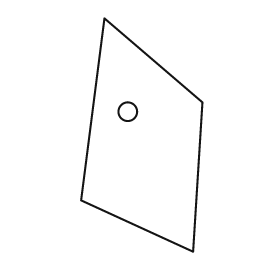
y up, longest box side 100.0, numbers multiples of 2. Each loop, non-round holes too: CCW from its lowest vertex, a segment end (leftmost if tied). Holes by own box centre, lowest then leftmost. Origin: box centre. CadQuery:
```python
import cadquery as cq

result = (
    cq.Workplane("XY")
    .moveTo(22.0, -50.0)
    .lineTo(26.0, 14.0)
    .lineTo(-16.0, 50.0)
    .lineTo(-26.0, -28.0)
    .close()
    .moveTo(-6.0, 10.0)
    .circle(4.0)
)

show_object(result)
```